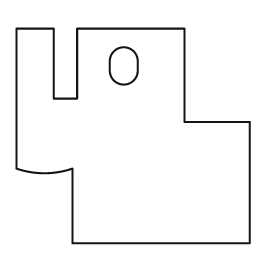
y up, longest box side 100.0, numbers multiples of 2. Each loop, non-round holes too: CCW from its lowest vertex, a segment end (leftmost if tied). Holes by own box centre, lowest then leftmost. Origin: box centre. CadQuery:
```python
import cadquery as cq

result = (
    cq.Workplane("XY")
    .moveTo(-26.0, -46.0)
    .lineTo(50.0, -46.0)
    .lineTo(50.0, 6.0)
    .lineTo(22.0, 6.0)
    .lineTo(22.0, 46.0)
    .lineTo(-24.0, 46.0)
    .lineTo(-24.0, 16.0)
    .lineTo(-34.0, 16.0)
    .lineTo(-34.0, 46.0)
    .lineTo(-50.0, 46.0)
    .lineTo(-50.0, -14.0)
    .threePointArc((-38.0, -16.0), (-26.0, -14.0))
    .close()
    .moveTo(-10.0, 28.0)
    .threePointArc((-4.0, 22.0), (2.0, 28.0))
    .lineTo(2.0, 32.0)
    .threePointArc((-4.0, 38.0), (-10.0, 32.0))
    .close()
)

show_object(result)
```